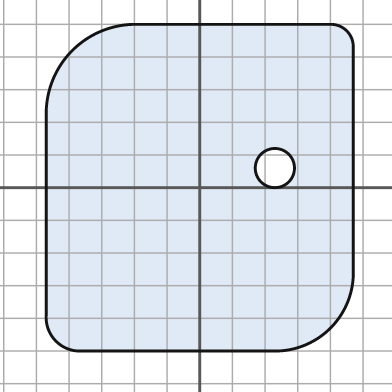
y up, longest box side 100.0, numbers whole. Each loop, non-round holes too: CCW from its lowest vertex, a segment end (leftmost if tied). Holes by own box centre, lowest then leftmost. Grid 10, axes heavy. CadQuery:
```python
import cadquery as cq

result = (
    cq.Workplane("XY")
    .moveTo(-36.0, -50.0)
    .lineTo(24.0, -50.0)
    .threePointArc((40.0, -43.0), (47.0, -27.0))
    .lineTo(47.0, 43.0)
    .threePointArc((45.0, 48.0), (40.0, 50.0))
    .lineTo(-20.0, 50.0)
    .threePointArc((-39.0, 42.0), (-47.0, 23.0))
    .lineTo(-47.0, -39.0)
    .threePointArc((-44.0, -47.0), (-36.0, -50.0))
    .close()
    .moveTo(23.0, 6.0)
    .circle(6.0)
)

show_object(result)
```